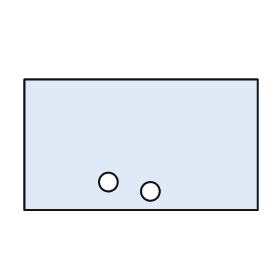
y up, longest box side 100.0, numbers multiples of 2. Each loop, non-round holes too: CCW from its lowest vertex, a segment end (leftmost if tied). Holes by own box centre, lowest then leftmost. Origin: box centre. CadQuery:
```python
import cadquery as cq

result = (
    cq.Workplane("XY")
    .moveTo(-50.0, -28.0)
    .lineTo(50.0, -28.0)
    .lineTo(50.0, 28.0)
    .lineTo(-50.0, 28.0)
    .close()
    .moveTo(4.0, -20.0)
    .circle(4.0)
    .moveTo(-14.0, -16.0)
    .circle(4.0)
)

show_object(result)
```